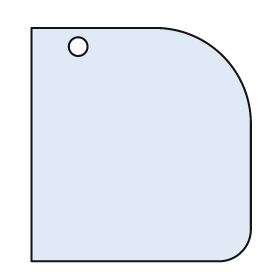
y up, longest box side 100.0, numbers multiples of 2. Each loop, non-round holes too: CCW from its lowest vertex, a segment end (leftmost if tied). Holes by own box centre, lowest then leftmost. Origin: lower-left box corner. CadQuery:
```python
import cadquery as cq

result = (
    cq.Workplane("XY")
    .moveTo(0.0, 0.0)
    .lineTo(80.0, 0.0)
    .threePointArc((90.0, 4.0), (94.0, 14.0))
    .lineTo(94.0, 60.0)
    .threePointArc((82.0, 88.0), (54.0, 100.0))
    .lineTo(0.0, 100.0)
    .close()
    .moveTo(20.0, 92.0)
    .circle(4.0)
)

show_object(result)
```